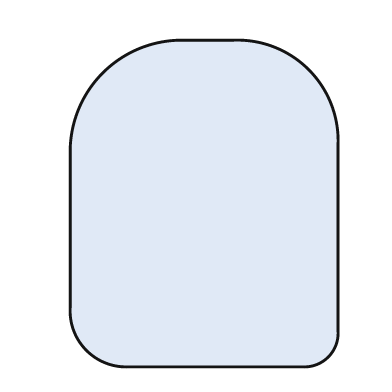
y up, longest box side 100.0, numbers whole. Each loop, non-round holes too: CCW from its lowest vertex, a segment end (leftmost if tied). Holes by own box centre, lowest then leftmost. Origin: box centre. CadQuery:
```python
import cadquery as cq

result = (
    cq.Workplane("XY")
    .moveTo(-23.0, -50.0)
    .lineTo(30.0, -50.0)
    .threePointArc((38.0, -47.0), (41.0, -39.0))
    .lineTo(41.0, 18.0)
    .threePointArc((32.0, 41.0), (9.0, 50.0))
    .lineTo(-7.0, 50.0)
    .threePointArc((-31.0, 40.0), (-41.0, 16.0))
    .lineTo(-41.0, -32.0)
    .threePointArc((-36.0, -45.0), (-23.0, -50.0))
    .close()
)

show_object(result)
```